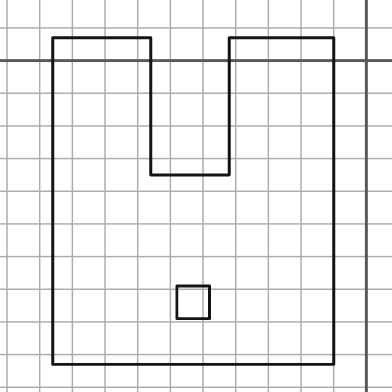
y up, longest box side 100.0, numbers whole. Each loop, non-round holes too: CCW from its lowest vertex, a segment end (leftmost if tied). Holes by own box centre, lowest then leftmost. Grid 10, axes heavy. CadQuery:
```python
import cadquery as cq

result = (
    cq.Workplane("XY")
    .moveTo(-96.0, -93.0)
    .lineTo(-10.0, -93.0)
    .lineTo(-10.0, 7.0)
    .lineTo(-42.0, 7.0)
    .lineTo(-42.0, -35.0)
    .lineTo(-66.0, -35.0)
    .lineTo(-66.0, 7.0)
    .lineTo(-96.0, 7.0)
    .close()
    .moveTo(-58.0, -79.0)
    .lineTo(-48.0, -79.0)
    .lineTo(-48.0, -69.0)
    .lineTo(-58.0, -69.0)
    .close()
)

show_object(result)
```